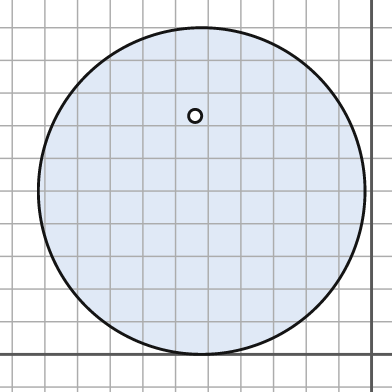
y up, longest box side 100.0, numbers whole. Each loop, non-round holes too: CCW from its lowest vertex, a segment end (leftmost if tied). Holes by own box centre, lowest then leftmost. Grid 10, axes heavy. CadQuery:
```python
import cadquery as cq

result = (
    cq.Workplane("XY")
    .moveTo(-52.0, 50.0)
    .circle(50.0)
    .moveTo(-54.0, 73.0)
    .circle(2.0)
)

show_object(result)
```